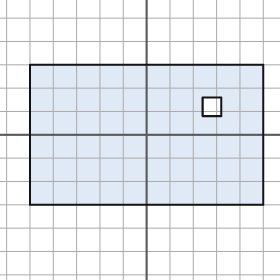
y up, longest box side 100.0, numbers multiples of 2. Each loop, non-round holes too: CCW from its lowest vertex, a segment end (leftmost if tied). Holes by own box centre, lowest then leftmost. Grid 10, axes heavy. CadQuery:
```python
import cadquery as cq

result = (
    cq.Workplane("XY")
    .moveTo(-50.0, -30.0)
    .lineTo(50.0, -30.0)
    .lineTo(50.0, 30.0)
    .lineTo(-50.0, 30.0)
    .close()
    .moveTo(24.0, 8.0)
    .lineTo(32.0, 8.0)
    .lineTo(32.0, 16.0)
    .lineTo(24.0, 16.0)
    .close()
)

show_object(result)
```